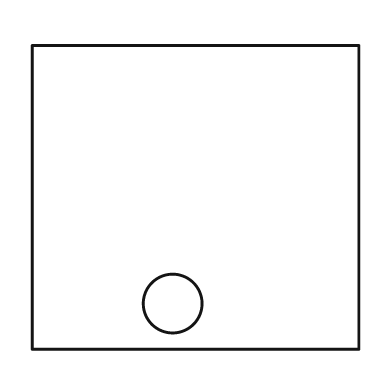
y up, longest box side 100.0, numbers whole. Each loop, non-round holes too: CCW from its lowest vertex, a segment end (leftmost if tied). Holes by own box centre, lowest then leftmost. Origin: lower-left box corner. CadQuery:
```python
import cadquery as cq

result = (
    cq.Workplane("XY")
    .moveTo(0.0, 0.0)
    .lineTo(100.0, 0.0)
    .lineTo(100.0, 93.0)
    .lineTo(0.0, 93.0)
    .close()
    .moveTo(43.0, 14.0)
    .circle(9.0)
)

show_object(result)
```